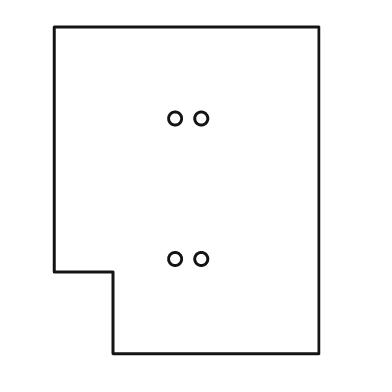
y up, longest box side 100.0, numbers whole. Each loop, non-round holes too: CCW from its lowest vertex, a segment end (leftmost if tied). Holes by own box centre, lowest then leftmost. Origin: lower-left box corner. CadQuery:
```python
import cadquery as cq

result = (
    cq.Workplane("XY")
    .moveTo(18.0, 0.0)
    .lineTo(81.0, 0.0)
    .lineTo(81.0, 100.0)
    .lineTo(0.0, 100.0)
    .lineTo(0.0, 25.0)
    .lineTo(18.0, 25.0)
    .close()
    .moveTo(37.0, 29.0)
    .circle(2.0)
    .moveTo(45.0, 29.0)
    .circle(2.0)
    .moveTo(37.0, 72.0)
    .circle(2.0)
    .moveTo(45.0, 72.0)
    .circle(2.0)
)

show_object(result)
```